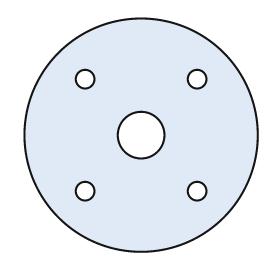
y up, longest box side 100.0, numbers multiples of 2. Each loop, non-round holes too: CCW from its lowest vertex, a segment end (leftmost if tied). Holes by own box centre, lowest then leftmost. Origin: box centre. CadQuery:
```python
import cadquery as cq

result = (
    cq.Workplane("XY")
    .moveTo(0.0, 0.0)
    .circle(50.0)
    .moveTo(-24.0, -24.0)
    .circle(4.0)
    .moveTo(24.0, -24.0)
    .circle(4.0)
    .moveTo(0.0, 0.0)
    .circle(10.0)
    .moveTo(-24.0, 24.0)
    .circle(4.0)
    .moveTo(24.0, 24.0)
    .circle(4.0)
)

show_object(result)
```